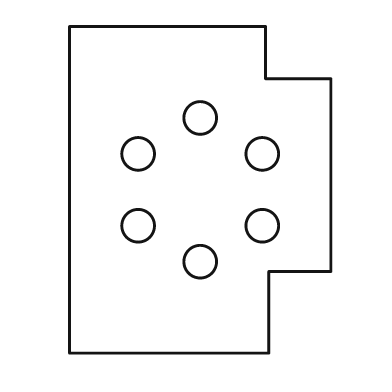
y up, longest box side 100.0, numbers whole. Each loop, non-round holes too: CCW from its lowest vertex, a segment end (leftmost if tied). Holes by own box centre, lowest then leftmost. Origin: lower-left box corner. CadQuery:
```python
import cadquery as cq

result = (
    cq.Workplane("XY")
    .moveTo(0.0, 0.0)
    .lineTo(61.0, 0.0)
    .lineTo(61.0, 25.0)
    .lineTo(80.0, 25.0)
    .lineTo(80.0, 84.0)
    .lineTo(60.0, 84.0)
    .lineTo(60.0, 100.0)
    .lineTo(0.0, 100.0)
    .close()
    .moveTo(40.0, 28.0)
    .circle(5.0)
    .moveTo(21.0, 39.0)
    .circle(5.0)
    .moveTo(59.0, 39.0)
    .circle(5.0)
    .moveTo(21.0, 61.0)
    .circle(5.0)
    .moveTo(59.0, 61.0)
    .circle(5.0)
    .moveTo(40.0, 72.0)
    .circle(5.0)
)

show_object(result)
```